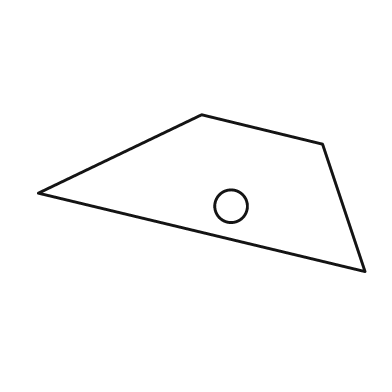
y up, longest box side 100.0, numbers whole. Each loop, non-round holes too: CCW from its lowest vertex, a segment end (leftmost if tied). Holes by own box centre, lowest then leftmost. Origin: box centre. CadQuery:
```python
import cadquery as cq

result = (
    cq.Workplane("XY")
    .moveTo(50.0, -24.0)
    .lineTo(37.0, 15.0)
    .lineTo(0.0, 24.0)
    .lineTo(-50.0, 0.0)
    .close()
    .moveTo(9.0, -4.0)
    .circle(5.0)
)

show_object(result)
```